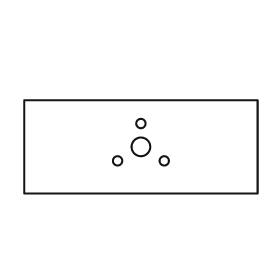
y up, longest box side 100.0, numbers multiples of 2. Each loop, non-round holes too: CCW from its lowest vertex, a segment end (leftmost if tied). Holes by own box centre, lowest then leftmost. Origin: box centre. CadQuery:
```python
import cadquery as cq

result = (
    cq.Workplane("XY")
    .moveTo(-50.0, -20.0)
    .lineTo(50.0, -20.0)
    .lineTo(50.0, 20.0)
    .lineTo(-50.0, 20.0)
    .close()
    .moveTo(-10.0, -6.0)
    .circle(2.0)
    .moveTo(10.0, -6.0)
    .circle(2.0)
    .moveTo(0.0, 0.0)
    .circle(4.0)
    .moveTo(0.0, 10.0)
    .circle(2.0)
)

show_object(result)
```